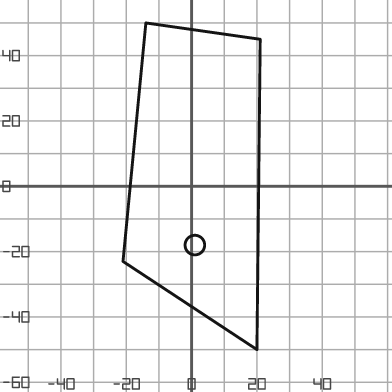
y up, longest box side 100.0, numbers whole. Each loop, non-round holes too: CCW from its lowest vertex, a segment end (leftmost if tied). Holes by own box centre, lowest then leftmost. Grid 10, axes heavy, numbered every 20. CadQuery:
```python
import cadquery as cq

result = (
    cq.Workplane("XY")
    .moveTo(20.0, -50.0)
    .lineTo(21.0, 45.0)
    .lineTo(-14.0, 50.0)
    .lineTo(-21.0, -23.0)
    .close()
    .moveTo(1.0, -18.0)
    .circle(3.0)
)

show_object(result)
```